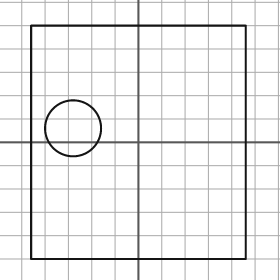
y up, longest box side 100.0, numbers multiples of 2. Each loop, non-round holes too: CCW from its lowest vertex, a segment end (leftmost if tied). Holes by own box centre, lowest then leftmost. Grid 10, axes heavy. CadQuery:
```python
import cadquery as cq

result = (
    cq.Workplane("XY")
    .moveTo(-46.0, -50.0)
    .lineTo(46.0, -50.0)
    .lineTo(46.0, 50.0)
    .lineTo(-46.0, 50.0)
    .close()
    .moveTo(-28.0, 6.0)
    .circle(12.0)
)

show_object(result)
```